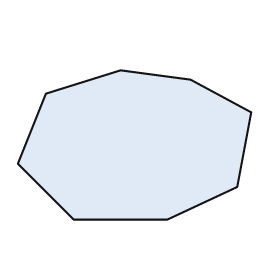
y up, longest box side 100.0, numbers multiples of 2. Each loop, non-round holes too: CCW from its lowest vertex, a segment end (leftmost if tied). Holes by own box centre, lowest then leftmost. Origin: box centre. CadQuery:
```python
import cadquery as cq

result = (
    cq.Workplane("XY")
    .moveTo(-26.0, -32.0)
    .lineTo(14.0, -32.0)
    .lineTo(44.0, -18.0)
    .lineTo(50.0, 14.0)
    .lineTo(24.0, 28.0)
    .lineTo(-6.0, 32.0)
    .lineTo(-38.0, 22.0)
    .lineTo(-50.0, -8.0)
    .close()
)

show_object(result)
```